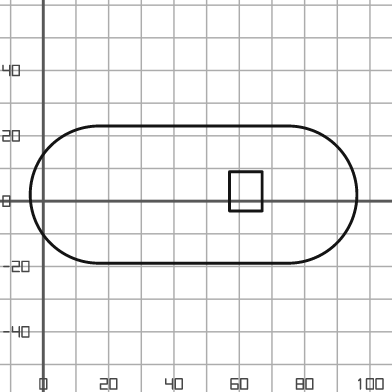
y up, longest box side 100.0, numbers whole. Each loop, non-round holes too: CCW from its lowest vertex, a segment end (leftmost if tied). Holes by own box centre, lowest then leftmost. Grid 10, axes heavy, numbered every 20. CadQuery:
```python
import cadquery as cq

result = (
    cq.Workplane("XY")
    .moveTo(17.0, -19.0)
    .lineTo(75.0, -19.0)
    .threePointArc((96.0, 2.0), (75.0, 23.0))
    .lineTo(17.0, 23.0)
    .threePointArc((-4.0, 2.0), (17.0, -19.0))
    .close()
    .moveTo(57.0, -3.0)
    .lineTo(67.0, -3.0)
    .lineTo(67.0, 9.0)
    .lineTo(57.0, 9.0)
    .close()
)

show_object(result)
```